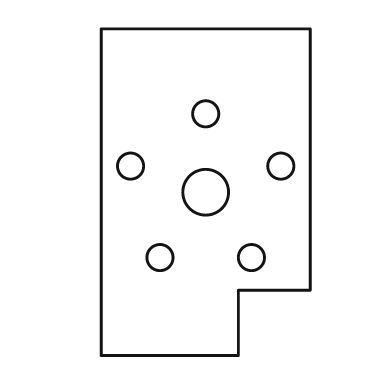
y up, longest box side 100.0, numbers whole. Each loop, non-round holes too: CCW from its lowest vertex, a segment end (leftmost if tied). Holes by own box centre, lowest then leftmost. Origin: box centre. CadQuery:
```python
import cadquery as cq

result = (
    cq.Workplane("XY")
    .moveTo(-32.0, -50.0)
    .lineTo(10.0, -50.0)
    .lineTo(10.0, -30.0)
    .lineTo(32.0, -30.0)
    .lineTo(32.0, 50.0)
    .lineTo(-32.0, 50.0)
    .close()
    .moveTo(-14.0, -20.0)
    .circle(4.0)
    .moveTo(14.0, -20.0)
    .circle(4.0)
    .moveTo(0.0, 0.0)
    .circle(7.0)
    .moveTo(-23.0, 8.0)
    .circle(4.0)
    .moveTo(23.0, 8.0)
    .circle(4.0)
    .moveTo(0.0, 24.0)
    .circle(4.0)
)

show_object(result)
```